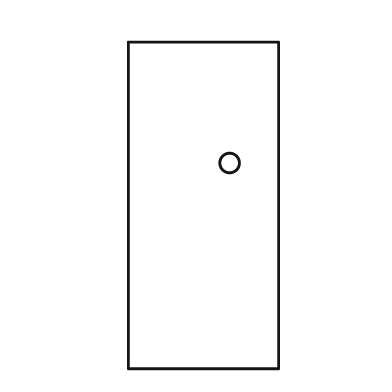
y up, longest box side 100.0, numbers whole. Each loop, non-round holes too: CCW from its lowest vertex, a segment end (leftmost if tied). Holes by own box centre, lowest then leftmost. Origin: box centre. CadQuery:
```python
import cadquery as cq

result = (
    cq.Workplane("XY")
    .moveTo(-23.0, -50.0)
    .lineTo(23.0, -50.0)
    .lineTo(23.0, 50.0)
    .lineTo(-23.0, 50.0)
    .close()
    .moveTo(8.0, 13.0)
    .circle(3.0)
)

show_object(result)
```